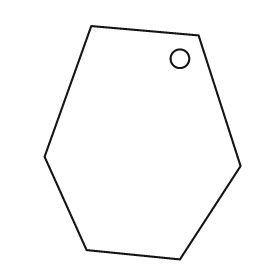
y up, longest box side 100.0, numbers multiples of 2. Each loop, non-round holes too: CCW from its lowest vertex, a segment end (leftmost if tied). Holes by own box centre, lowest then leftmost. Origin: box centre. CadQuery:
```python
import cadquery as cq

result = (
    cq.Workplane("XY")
    .moveTo(16.0, -50.0)
    .lineTo(42.0, -10.0)
    .lineTo(24.0, 46.0)
    .lineTo(-22.0, 50.0)
    .lineTo(-42.0, -6.0)
    .lineTo(-24.0, -46.0)
    .close()
    .moveTo(16.0, 36.0)
    .circle(4.0)
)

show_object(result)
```